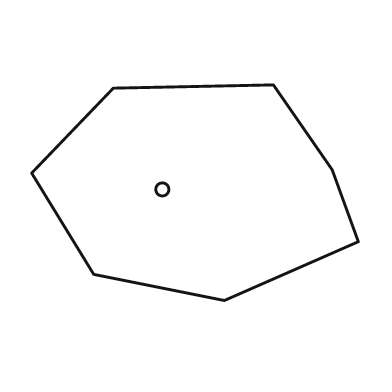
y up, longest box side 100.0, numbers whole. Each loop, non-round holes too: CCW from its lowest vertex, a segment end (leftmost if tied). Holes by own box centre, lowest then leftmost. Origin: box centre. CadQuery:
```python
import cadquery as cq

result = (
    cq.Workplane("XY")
    .moveTo(9.0, -33.0)
    .lineTo(50.0, -15.0)
    .lineTo(42.0, 7.0)
    .lineTo(24.0, 33.0)
    .lineTo(-25.0, 32.0)
    .lineTo(-50.0, 6.0)
    .lineTo(-31.0, -25.0)
    .close()
    .moveTo(-10.0, 1.0)
    .circle(2.0)
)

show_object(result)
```